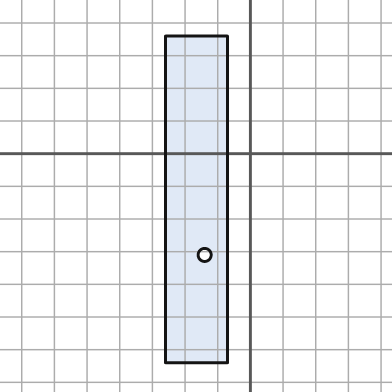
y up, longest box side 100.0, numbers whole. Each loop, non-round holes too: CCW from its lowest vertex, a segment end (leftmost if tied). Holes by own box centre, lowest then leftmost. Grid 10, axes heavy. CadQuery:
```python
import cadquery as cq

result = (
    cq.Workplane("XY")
    .moveTo(-26.0, -64.0)
    .lineTo(-7.0, -64.0)
    .lineTo(-7.0, 36.0)
    .lineTo(-26.0, 36.0)
    .close()
    .moveTo(-14.0, -31.0)
    .circle(2.0)
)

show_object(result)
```